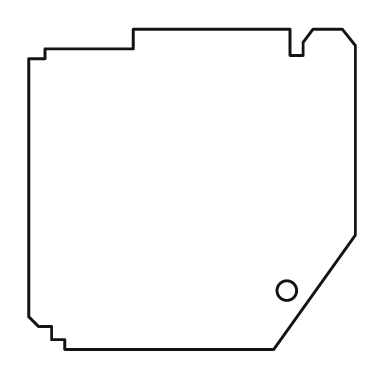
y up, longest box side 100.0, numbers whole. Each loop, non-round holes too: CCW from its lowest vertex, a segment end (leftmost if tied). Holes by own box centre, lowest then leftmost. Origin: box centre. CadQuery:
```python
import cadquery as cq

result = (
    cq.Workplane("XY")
    .moveTo(-39.0, -49.0)
    .lineTo(25.0, -49.0)
    .lineTo(50.0, -14.0)
    .lineTo(50.0, 44.0)
    .lineTo(46.0, 49.0)
    .lineTo(37.0, 49.0)
    .lineTo(34.0, 45.0)
    .lineTo(34.0, 41.0)
    .lineTo(30.0, 41.0)
    .lineTo(30.0, 49.0)
    .lineTo(-18.0, 49.0)
    .lineTo(-18.0, 43.0)
    .lineTo(-45.0, 43.0)
    .lineTo(-45.0, 40.0)
    .lineTo(-50.0, 40.0)
    .lineTo(-50.0, -39.0)
    .lineTo(-47.0, -42.0)
    .lineTo(-43.0, -42.0)
    .lineTo(-43.0, -46.0)
    .lineTo(-39.0, -46.0)
    .close()
    .moveTo(29.0, -31.0)
    .circle(3.0)
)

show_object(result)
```